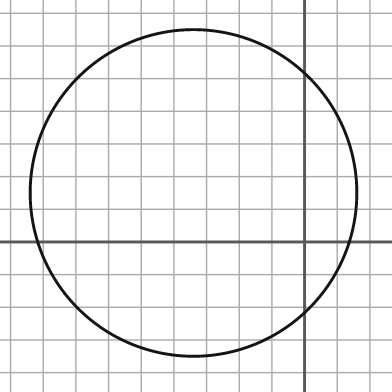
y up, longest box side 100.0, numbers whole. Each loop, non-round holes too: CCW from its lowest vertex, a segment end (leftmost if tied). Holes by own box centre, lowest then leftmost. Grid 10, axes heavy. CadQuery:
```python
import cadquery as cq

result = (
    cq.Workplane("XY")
    .moveTo(-34.0, 15.0)
    .circle(50.0)
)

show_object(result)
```